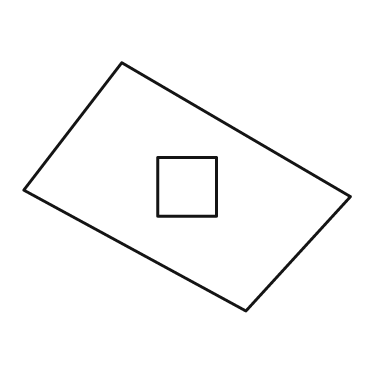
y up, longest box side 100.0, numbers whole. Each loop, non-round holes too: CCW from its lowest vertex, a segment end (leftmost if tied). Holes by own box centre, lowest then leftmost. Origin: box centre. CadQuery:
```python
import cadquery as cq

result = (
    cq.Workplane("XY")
    .moveTo(18.0, -38.0)
    .lineTo(50.0, -3.0)
    .lineTo(-20.0, 38.0)
    .lineTo(-50.0, -1.0)
    .close()
    .moveTo(-9.0, -9.0)
    .lineTo(9.0, -9.0)
    .lineTo(9.0, 9.0)
    .lineTo(-9.0, 9.0)
    .close()
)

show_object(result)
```